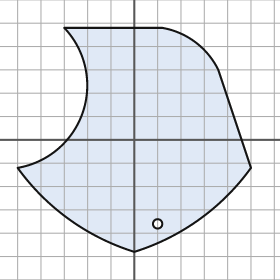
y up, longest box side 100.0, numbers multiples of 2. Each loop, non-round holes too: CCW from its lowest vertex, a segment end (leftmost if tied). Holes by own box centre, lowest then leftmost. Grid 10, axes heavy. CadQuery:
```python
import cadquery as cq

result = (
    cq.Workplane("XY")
    .moveTo(0.0, -48.0)
    .threePointArc((28.0, -34.0), (50.0, -12.0))
    .lineTo(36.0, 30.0)
    .threePointArc((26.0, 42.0), (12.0, 48.0))
    .lineTo(-30.0, 48.0)
    .threePointArc((-22.0, 12.0), (-50.0, -12.0))
    .threePointArc((-28.0, -34.0), (0.0, -48.0))
    .close()
    .moveTo(10.0, -36.0)
    .circle(2.0)
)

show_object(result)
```